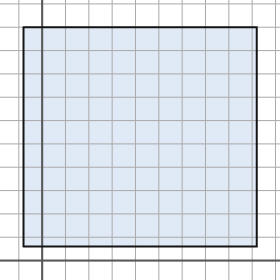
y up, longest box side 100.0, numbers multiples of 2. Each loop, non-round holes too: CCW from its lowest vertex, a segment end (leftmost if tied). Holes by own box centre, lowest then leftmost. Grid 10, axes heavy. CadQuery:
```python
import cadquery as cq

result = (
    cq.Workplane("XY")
    .moveTo(-8.0, 6.0)
    .lineTo(92.0, 6.0)
    .lineTo(92.0, 100.0)
    .lineTo(-8.0, 100.0)
    .close()
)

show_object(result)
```